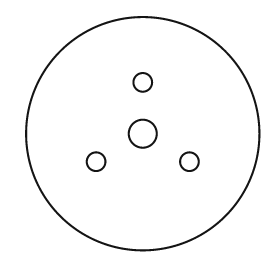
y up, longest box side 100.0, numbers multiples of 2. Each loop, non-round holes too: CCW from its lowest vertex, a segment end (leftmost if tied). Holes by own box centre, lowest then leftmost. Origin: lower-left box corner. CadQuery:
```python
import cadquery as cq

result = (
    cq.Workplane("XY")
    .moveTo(50.0, 50.0)
    .circle(50.0)
    .moveTo(30.0, 38.0)
    .circle(4.0)
    .moveTo(70.0, 38.0)
    .circle(4.0)
    .moveTo(50.0, 50.0)
    .circle(6.0)
    .moveTo(50.0, 72.0)
    .circle(4.0)
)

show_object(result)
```